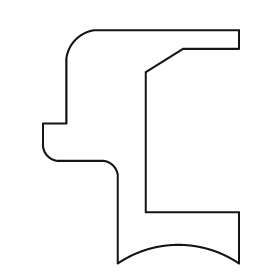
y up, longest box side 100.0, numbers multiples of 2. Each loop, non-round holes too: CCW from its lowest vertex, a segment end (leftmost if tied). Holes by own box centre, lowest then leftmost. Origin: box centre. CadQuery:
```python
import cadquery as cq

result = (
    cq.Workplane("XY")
    .moveTo(-10.0, -50.0)
    .threePointArc((16.0, -42.0), (42.0, -50.0))
    .lineTo(42.0, -28.0)
    .lineTo(2.0, -28.0)
    .lineTo(2.0, 32.0)
    .lineTo(18.0, 42.0)
    .lineTo(42.0, 42.0)
    .lineTo(42.0, 50.0)
    .lineTo(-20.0, 50.0)
    .threePointArc((-28.0, 46.0), (-32.0, 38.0))
    .lineTo(-32.0, 10.0)
    .lineTo(-42.0, 10.0)
    .lineTo(-42.0, 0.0)
    .threePointArc((-40.0, -4.0), (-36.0, -6.0))
    .lineTo(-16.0, -6.0)
    .threePointArc((-12.0, -8.0), (-10.0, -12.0))
    .close()
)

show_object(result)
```